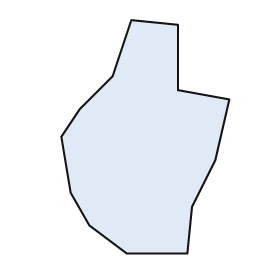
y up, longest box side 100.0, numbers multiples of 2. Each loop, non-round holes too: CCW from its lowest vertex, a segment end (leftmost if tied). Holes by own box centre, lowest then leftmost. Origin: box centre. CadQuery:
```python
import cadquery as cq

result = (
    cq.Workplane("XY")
    .moveTo(-8.0, -50.0)
    .lineTo(18.0, -50.0)
    .lineTo(20.0, -30.0)
    .lineTo(30.0, -10.0)
    .lineTo(36.0, 16.0)
    .lineTo(14.0, 20.0)
    .lineTo(14.0, 48.0)
    .lineTo(-6.0, 50.0)
    .lineTo(-14.0, 26.0)
    .lineTo(-28.0, 12.0)
    .lineTo(-36.0, 0.0)
    .lineTo(-32.0, -24.0)
    .lineTo(-24.0, -38.0)
    .close()
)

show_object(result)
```